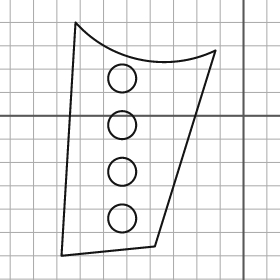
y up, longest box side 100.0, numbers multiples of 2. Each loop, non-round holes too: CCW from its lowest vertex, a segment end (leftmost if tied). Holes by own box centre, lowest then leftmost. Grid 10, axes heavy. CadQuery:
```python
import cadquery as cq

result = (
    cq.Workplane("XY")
    .moveTo(-78.0, -60.0)
    .lineTo(-38.0, -56.0)
    .lineTo(-12.0, 28.0)
    .threePointArc((-44.0, 24.0), (-72.0, 40.0))
    .close()
    .moveTo(-52.0, -44.0)
    .circle(6.0)
    .moveTo(-52.0, -24.0)
    .circle(6.0)
    .moveTo(-52.0, -4.0)
    .circle(6.0)
    .moveTo(-52.0, 16.0)
    .circle(6.0)
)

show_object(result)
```